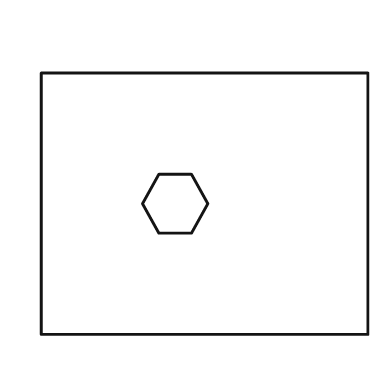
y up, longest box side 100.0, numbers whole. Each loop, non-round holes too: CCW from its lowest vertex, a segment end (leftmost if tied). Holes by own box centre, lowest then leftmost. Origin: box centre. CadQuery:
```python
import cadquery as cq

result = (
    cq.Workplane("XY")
    .moveTo(-50.0, -40.0)
    .lineTo(50.0, -40.0)
    .lineTo(50.0, 40.0)
    .lineTo(-50.0, 40.0)
    .close()
    .moveTo(-14.0, -9.0)
    .lineTo(-4.0, -9.0)
    .lineTo(1.0, 0.0)
    .lineTo(-4.0, 9.0)
    .lineTo(-14.0, 9.0)
    .lineTo(-19.0, 0.0)
    .close()
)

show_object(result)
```